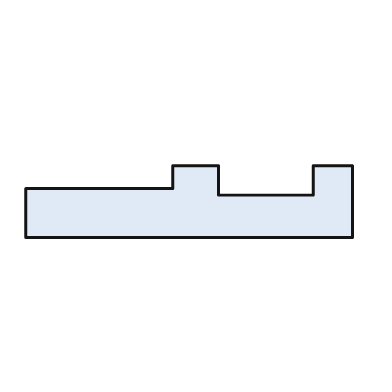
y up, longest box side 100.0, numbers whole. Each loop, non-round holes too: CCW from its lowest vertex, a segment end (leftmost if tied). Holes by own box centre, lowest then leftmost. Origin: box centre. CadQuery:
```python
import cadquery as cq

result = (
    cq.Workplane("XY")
    .moveTo(-50.0, -11.0)
    .lineTo(50.0, -11.0)
    .lineTo(50.0, 11.0)
    .lineTo(38.0, 11.0)
    .lineTo(38.0, 2.0)
    .lineTo(9.0, 2.0)
    .lineTo(9.0, 11.0)
    .lineTo(-5.0, 11.0)
    .lineTo(-5.0, 4.0)
    .lineTo(-50.0, 4.0)
    .close()
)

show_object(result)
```